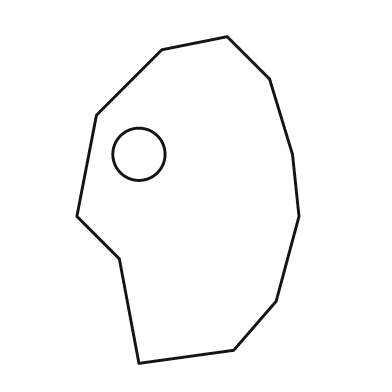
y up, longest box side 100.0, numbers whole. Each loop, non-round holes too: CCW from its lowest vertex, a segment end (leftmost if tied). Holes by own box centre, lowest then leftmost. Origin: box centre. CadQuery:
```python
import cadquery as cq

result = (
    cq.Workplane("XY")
    .moveTo(-15.0, -50.0)
    .lineTo(14.0, -46.0)
    .lineTo(27.0, -31.0)
    .lineTo(34.0, -5.0)
    .lineTo(32.0, 14.0)
    .lineTo(25.0, 37.0)
    .lineTo(12.0, 50.0)
    .lineTo(-8.0, 46.0)
    .lineTo(-28.0, 26.0)
    .lineTo(-34.0, -5.0)
    .lineTo(-21.0, -18.0)
    .close()
    .moveTo(-15.0, 14.0)
    .circle(8.0)
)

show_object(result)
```